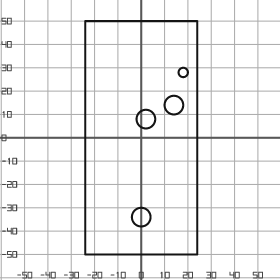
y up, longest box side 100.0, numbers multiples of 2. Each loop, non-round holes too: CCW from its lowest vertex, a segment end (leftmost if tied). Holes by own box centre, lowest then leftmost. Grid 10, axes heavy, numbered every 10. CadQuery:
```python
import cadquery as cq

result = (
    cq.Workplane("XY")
    .moveTo(-24.0, -50.0)
    .lineTo(24.0, -50.0)
    .lineTo(24.0, 50.0)
    .lineTo(-24.0, 50.0)
    .close()
    .moveTo(0.0, -34.0)
    .circle(4.0)
    .moveTo(2.0, 8.0)
    .circle(4.0)
    .moveTo(14.0, 14.0)
    .circle(4.0)
    .moveTo(18.0, 28.0)
    .circle(2.0)
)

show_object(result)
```